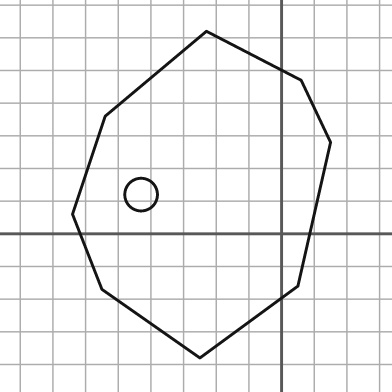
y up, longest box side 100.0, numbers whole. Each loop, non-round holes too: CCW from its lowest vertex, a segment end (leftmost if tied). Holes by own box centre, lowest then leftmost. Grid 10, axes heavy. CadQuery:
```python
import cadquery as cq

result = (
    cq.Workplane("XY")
    .moveTo(-25.0, -38.0)
    .lineTo(5.0, -16.0)
    .lineTo(15.0, 28.0)
    .lineTo(6.0, 47.0)
    .lineTo(-23.0, 62.0)
    .lineTo(-54.0, 36.0)
    .lineTo(-64.0, 6.0)
    .lineTo(-55.0, -17.0)
    .close()
    .moveTo(-43.0, 12.0)
    .circle(5.0)
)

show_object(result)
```